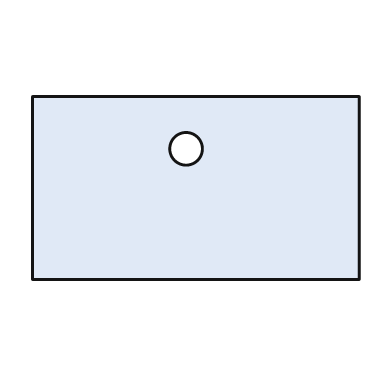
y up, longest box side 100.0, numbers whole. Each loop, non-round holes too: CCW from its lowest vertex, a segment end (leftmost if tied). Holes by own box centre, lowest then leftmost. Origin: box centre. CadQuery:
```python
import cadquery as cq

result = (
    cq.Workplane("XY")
    .moveTo(-50.0, -28.0)
    .lineTo(50.0, -28.0)
    .lineTo(50.0, 28.0)
    .lineTo(-50.0, 28.0)
    .close()
    .moveTo(-3.0, 12.0)
    .circle(5.0)
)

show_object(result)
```